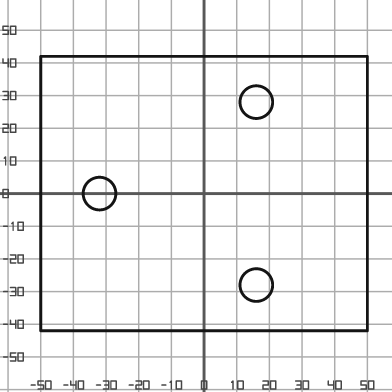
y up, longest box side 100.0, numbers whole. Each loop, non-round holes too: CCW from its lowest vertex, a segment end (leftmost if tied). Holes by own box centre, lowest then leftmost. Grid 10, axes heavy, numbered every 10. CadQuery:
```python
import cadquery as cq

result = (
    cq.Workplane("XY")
    .moveTo(-50.0, -42.0)
    .lineTo(50.0, -42.0)
    .lineTo(50.0, 42.0)
    .lineTo(-50.0, 42.0)
    .close()
    .moveTo(16.0, -28.0)
    .circle(5.0)
    .moveTo(-32.0, 0.0)
    .circle(5.0)
    .moveTo(16.0, 28.0)
    .circle(5.0)
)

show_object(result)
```